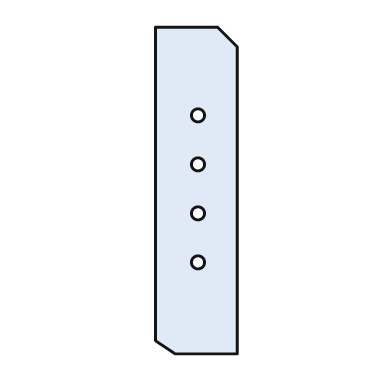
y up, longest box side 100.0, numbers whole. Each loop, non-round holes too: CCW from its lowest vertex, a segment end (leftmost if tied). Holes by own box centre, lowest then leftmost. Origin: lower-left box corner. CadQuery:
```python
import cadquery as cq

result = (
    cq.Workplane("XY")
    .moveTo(6.0, 0.0)
    .lineTo(25.0, 0.0)
    .lineTo(25.0, 94.0)
    .lineTo(19.0, 100.0)
    .lineTo(0.0, 100.0)
    .lineTo(0.0, 4.0)
    .close()
    .moveTo(13.0, 28.0)
    .circle(2.0)
    .moveTo(13.0, 43.0)
    .circle(2.0)
    .moveTo(13.0, 58.0)
    .circle(2.0)
    .moveTo(13.0, 73.0)
    .circle(2.0)
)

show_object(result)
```